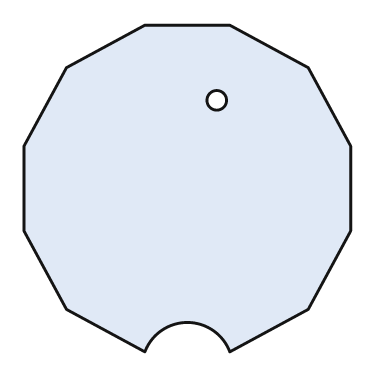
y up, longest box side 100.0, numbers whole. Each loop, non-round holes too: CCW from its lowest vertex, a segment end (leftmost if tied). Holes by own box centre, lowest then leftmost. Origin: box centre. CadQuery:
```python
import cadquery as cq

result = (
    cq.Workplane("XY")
    .moveTo(-13.0, -50.0)
    .threePointArc((0.0, -41.0), (13.0, -50.0))
    .lineTo(37.0, -37.0)
    .lineTo(50.0, -13.0)
    .lineTo(50.0, 13.0)
    .lineTo(37.0, 37.0)
    .lineTo(13.0, 50.0)
    .lineTo(-13.0, 50.0)
    .lineTo(-37.0, 37.0)
    .lineTo(-50.0, 13.0)
    .lineTo(-50.0, -13.0)
    .lineTo(-37.0, -37.0)
    .close()
    .moveTo(9.0, 27.0)
    .circle(3.0)
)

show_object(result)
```